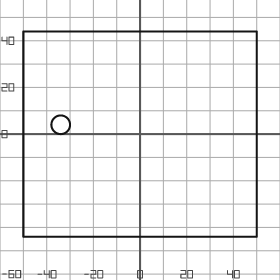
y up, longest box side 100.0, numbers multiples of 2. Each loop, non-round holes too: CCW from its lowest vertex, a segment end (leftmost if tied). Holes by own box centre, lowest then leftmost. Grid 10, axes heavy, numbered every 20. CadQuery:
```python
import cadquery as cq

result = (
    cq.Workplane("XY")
    .moveTo(-50.0, -44.0)
    .lineTo(50.0, -44.0)
    .lineTo(50.0, 44.0)
    .lineTo(-50.0, 44.0)
    .close()
    .moveTo(-34.0, 4.0)
    .circle(4.0)
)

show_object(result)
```